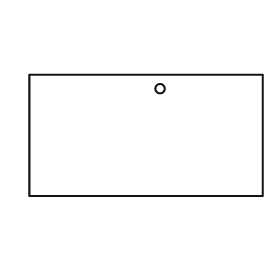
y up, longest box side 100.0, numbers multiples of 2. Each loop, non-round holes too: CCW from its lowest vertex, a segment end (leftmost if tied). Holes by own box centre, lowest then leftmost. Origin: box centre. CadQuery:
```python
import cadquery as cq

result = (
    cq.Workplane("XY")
    .moveTo(-50.0, -26.0)
    .lineTo(50.0, -26.0)
    .lineTo(50.0, 26.0)
    .lineTo(-50.0, 26.0)
    .close()
    .moveTo(6.0, 20.0)
    .circle(2.0)
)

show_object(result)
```